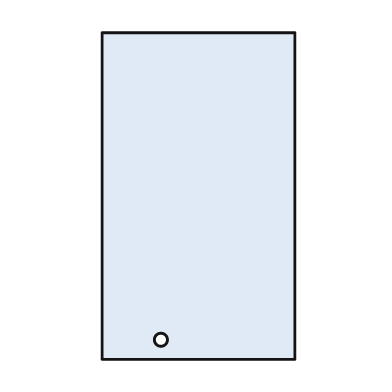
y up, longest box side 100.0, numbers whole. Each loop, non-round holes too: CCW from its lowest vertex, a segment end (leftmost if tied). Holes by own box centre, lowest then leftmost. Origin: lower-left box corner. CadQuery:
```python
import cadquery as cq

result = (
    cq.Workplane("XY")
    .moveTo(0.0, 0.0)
    .lineTo(59.0, 0.0)
    .lineTo(59.0, 100.0)
    .lineTo(0.0, 100.0)
    .close()
    .moveTo(18.0, 6.0)
    .circle(2.0)
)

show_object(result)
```